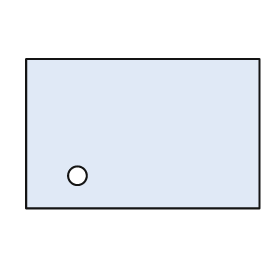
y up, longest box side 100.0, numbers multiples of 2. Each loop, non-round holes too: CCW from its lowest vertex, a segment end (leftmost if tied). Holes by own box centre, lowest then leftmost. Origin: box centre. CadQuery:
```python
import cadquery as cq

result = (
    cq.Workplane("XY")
    .moveTo(-50.0, -32.0)
    .lineTo(50.0, -32.0)
    .lineTo(50.0, 32.0)
    .lineTo(-50.0, 32.0)
    .close()
    .moveTo(-28.0, -18.0)
    .circle(4.0)
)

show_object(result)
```